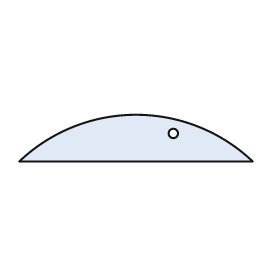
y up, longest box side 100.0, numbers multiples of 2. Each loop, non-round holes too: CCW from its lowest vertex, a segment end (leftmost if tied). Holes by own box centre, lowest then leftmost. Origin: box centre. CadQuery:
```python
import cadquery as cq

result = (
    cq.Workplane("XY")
    .moveTo(-50.0, -10.0)
    .lineTo(50.0, -10.0)
    .threePointArc((0.0, 10.0), (-50.0, -10.0))
    .close()
    .moveTo(16.0, 2.0)
    .circle(2.0)
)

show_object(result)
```